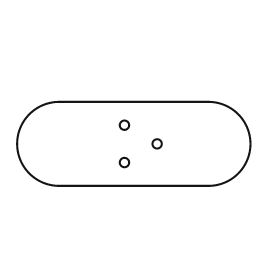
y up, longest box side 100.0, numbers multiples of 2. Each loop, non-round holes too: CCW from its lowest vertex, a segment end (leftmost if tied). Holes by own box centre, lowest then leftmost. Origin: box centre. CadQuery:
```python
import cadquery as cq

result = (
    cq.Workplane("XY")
    .moveTo(-32.0, -18.0)
    .lineTo(32.0, -18.0)
    .threePointArc((50.0, 0.0), (32.0, 18.0))
    .lineTo(-32.0, 18.0)
    .threePointArc((-50.0, 0.0), (-32.0, -18.0))
    .close()
    .moveTo(-4.0, -8.0)
    .circle(2.0)
    .moveTo(10.0, 0.0)
    .circle(2.0)
    .moveTo(-4.0, 8.0)
    .circle(2.0)
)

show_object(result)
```